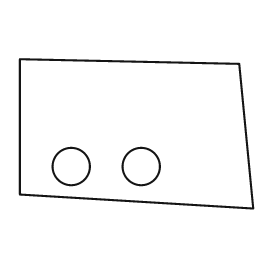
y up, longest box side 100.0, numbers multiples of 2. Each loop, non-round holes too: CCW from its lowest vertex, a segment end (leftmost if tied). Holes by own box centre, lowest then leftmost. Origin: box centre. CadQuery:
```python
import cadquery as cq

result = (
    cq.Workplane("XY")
    .moveTo(50.0, -32.0)
    .lineTo(44.0, 30.0)
    .lineTo(-50.0, 32.0)
    .lineTo(-50.0, -26.0)
    .close()
    .moveTo(-28.0, -14.0)
    .circle(8.0)
    .moveTo(2.0, -14.0)
    .circle(8.0)
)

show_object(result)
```